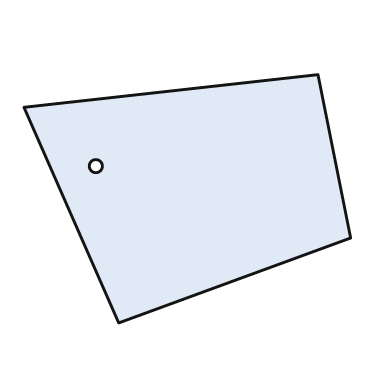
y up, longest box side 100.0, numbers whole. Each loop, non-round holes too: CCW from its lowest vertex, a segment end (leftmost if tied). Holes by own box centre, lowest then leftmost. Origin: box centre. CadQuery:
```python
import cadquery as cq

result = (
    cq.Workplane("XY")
    .moveTo(-21.0, -38.0)
    .lineTo(50.0, -12.0)
    .lineTo(40.0, 38.0)
    .lineTo(-50.0, 28.0)
    .close()
    .moveTo(-28.0, 10.0)
    .circle(2.0)
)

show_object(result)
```